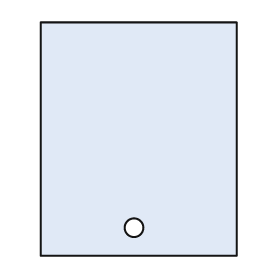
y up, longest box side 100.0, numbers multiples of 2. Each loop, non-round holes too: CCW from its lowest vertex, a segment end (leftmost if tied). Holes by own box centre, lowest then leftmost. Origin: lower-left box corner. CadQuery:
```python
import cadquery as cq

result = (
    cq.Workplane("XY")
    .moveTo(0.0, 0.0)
    .lineTo(84.0, 0.0)
    .lineTo(84.0, 100.0)
    .lineTo(0.0, 100.0)
    .close()
    .moveTo(40.0, 12.0)
    .circle(4.0)
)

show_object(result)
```